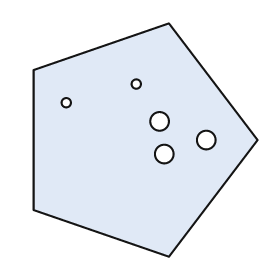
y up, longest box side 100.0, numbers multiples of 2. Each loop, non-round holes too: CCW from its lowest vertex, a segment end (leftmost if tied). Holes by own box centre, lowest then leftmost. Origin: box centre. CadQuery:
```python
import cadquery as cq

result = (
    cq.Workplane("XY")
    .moveTo(10.0, -50.0)
    .lineTo(48.0, 0.0)
    .lineTo(10.0, 50.0)
    .lineTo(-48.0, 30.0)
    .lineTo(-48.0, -30.0)
    .close()
    .moveTo(8.0, -6.0)
    .circle(4.0)
    .moveTo(26.0, 0.0)
    .circle(4.0)
    .moveTo(6.0, 8.0)
    .circle(4.0)
    .moveTo(-34.0, 16.0)
    .circle(2.0)
    .moveTo(-4.0, 24.0)
    .circle(2.0)
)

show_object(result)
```